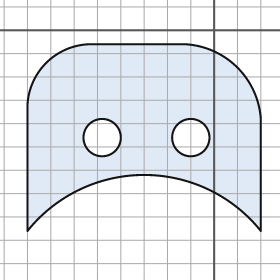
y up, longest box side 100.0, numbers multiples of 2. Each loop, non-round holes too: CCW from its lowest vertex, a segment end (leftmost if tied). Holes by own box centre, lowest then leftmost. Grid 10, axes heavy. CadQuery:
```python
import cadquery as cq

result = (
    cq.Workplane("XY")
    .moveTo(-80.0, -86.0)
    .threePointArc((-30.0, -62.0), (20.0, -86.0))
    .lineTo(20.0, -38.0)
    .threePointArc((10.0, -16.0), (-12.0, -6.0))
    .lineTo(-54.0, -6.0)
    .threePointArc((-72.0, -14.0), (-80.0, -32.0))
    .close()
    .moveTo(-48.0, -46.0)
    .circle(8.0)
    .moveTo(-10.0, -46.0)
    .circle(8.0)
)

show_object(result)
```